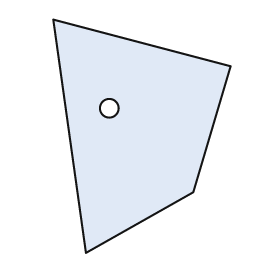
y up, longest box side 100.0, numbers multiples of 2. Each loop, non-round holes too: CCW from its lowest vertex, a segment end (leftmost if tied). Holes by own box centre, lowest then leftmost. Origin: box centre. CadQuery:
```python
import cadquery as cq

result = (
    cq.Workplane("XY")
    .moveTo(-24.0, -50.0)
    .lineTo(22.0, -24.0)
    .lineTo(38.0, 30.0)
    .lineTo(-38.0, 50.0)
    .close()
    .moveTo(-14.0, 12.0)
    .circle(4.0)
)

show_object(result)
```